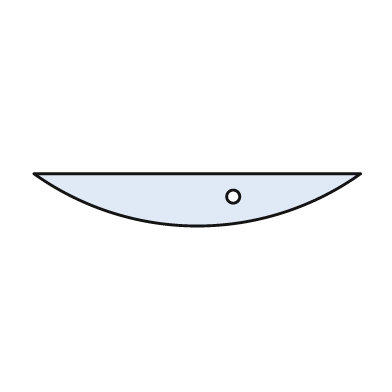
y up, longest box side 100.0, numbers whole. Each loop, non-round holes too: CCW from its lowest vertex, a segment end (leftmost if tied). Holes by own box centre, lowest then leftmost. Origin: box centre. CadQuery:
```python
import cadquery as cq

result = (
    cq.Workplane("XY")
    .moveTo(-50.0, 8.0)
    .threePointArc((0.0, -8.0), (50.0, 8.0))
    .close()
    .moveTo(11.0, 1.0)
    .circle(2.0)
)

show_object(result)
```